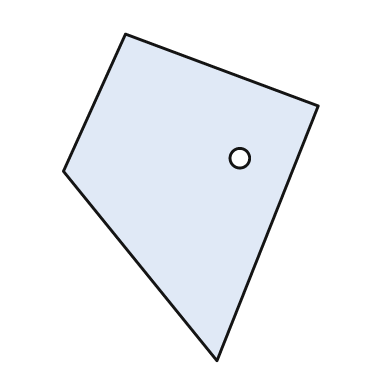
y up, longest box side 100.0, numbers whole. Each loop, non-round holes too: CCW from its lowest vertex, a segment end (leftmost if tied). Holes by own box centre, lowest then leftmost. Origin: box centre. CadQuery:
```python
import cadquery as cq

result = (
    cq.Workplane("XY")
    .moveTo(8.0, -50.0)
    .lineTo(39.0, 28.0)
    .lineTo(-20.0, 50.0)
    .lineTo(-39.0, 8.0)
    .close()
    .moveTo(15.0, 12.0)
    .circle(3.0)
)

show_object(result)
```